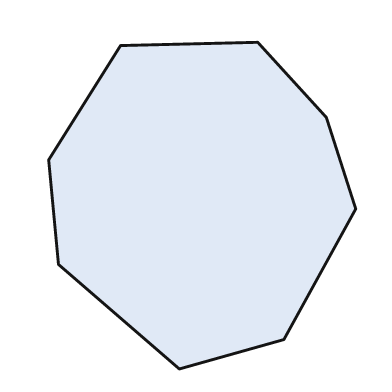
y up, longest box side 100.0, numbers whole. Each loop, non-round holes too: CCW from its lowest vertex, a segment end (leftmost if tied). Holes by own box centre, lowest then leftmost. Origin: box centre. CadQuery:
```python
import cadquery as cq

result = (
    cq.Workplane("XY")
    .moveTo(-7.0, -50.0)
    .lineTo(25.0, -41.0)
    .lineTo(47.0, -1.0)
    .lineTo(38.0, 27.0)
    .lineTo(17.0, 50.0)
    .lineTo(-25.0, 49.0)
    .lineTo(-47.0, 14.0)
    .lineTo(-44.0, -18.0)
    .close()
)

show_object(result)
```